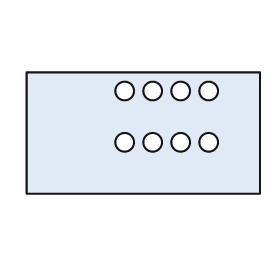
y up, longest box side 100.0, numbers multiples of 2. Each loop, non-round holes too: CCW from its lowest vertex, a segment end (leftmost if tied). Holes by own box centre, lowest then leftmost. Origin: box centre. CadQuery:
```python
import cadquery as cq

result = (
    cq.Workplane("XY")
    .moveTo(-50.0, -26.0)
    .lineTo(50.0, -26.0)
    .lineTo(50.0, 26.0)
    .lineTo(-50.0, 26.0)
    .close()
    .moveTo(-8.0, -4.0)
    .circle(4.0)
    .moveTo(4.0, -4.0)
    .circle(4.0)
    .moveTo(16.0, -4.0)
    .circle(4.0)
    .moveTo(28.0, -4.0)
    .circle(4.0)
    .moveTo(-8.0, 18.0)
    .circle(4.0)
    .moveTo(4.0, 18.0)
    .circle(4.0)
    .moveTo(16.0, 18.0)
    .circle(4.0)
    .moveTo(28.0, 18.0)
    .circle(4.0)
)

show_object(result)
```